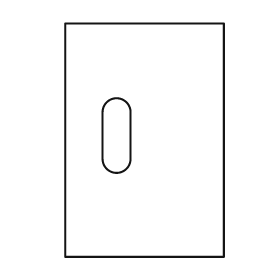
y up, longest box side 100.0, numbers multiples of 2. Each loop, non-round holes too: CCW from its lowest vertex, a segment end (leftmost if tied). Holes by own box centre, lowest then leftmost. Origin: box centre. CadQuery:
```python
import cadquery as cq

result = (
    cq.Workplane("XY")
    .moveTo(-34.0, -50.0)
    .lineTo(34.0, -50.0)
    .lineTo(34.0, 50.0)
    .lineTo(-34.0, 50.0)
    .close()
    .moveTo(-18.0, -8.0)
    .threePointArc((-12.0, -14.0), (-6.0, -8.0))
    .lineTo(-6.0, 12.0)
    .threePointArc((-12.0, 18.0), (-18.0, 12.0))
    .close()
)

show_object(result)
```